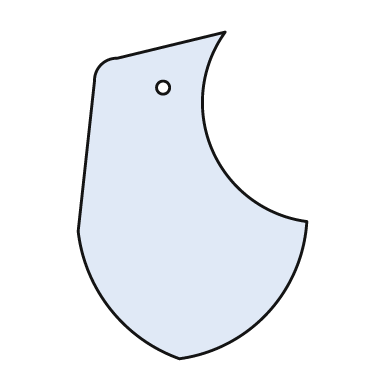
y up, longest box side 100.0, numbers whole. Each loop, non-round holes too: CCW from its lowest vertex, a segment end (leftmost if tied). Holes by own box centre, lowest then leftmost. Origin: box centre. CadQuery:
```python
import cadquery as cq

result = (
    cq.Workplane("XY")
    .moveTo(-4.0, -50.0)
    .threePointArc((23.0, -36.0), (35.0, -8.0))
    .threePointArc((6.0, 14.0), (10.0, 50.0))
    .lineTo(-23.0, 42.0)
    .threePointArc((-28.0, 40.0), (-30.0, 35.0))
    .lineTo(-35.0, -11.0)
    .threePointArc((-25.0, -35.0), (-4.0, -50.0))
    .close()
    .moveTo(-9.0, 33.0)
    .circle(2.0)
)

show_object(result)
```